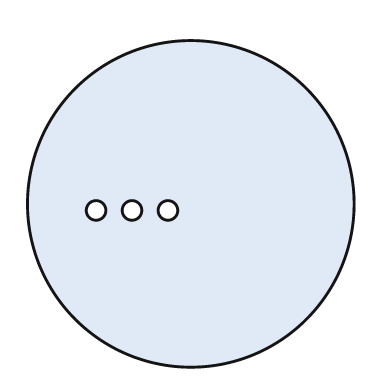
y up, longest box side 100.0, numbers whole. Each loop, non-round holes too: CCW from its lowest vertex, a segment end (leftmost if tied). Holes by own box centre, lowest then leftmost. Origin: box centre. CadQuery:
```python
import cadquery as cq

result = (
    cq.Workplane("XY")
    .moveTo(0.0, 0.0)
    .circle(50.0)
    .moveTo(-29.0, -2.0)
    .circle(3.0)
    .moveTo(-18.0, -2.0)
    .circle(3.0)
    .moveTo(-7.0, -2.0)
    .circle(3.0)
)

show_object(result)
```